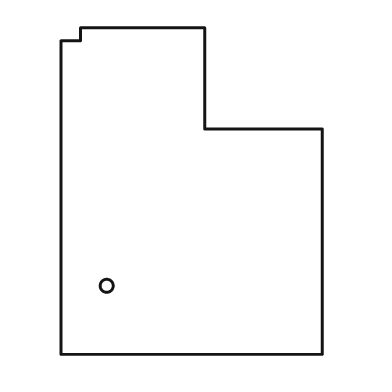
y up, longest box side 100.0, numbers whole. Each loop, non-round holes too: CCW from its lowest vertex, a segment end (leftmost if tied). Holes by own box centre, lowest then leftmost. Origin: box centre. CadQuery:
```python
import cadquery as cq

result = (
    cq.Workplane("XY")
    .moveTo(-40.0, -50.0)
    .lineTo(40.0, -50.0)
    .lineTo(40.0, 19.0)
    .lineTo(4.0, 19.0)
    .lineTo(4.0, 50.0)
    .lineTo(-34.0, 50.0)
    .lineTo(-34.0, 46.0)
    .lineTo(-40.0, 46.0)
    .close()
    .moveTo(-26.0, -29.0)
    .circle(2.0)
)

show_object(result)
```